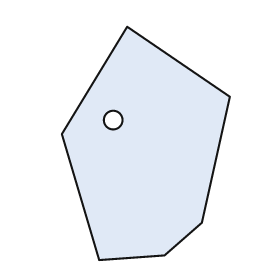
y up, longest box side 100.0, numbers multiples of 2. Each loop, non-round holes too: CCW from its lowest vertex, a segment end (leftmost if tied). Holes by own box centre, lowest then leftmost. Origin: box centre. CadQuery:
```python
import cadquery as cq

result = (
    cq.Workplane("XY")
    .moveTo(-20.0, -50.0)
    .lineTo(8.0, -48.0)
    .lineTo(24.0, -34.0)
    .lineTo(36.0, 20.0)
    .lineTo(-8.0, 50.0)
    .lineTo(-36.0, 4.0)
    .close()
    .moveTo(-14.0, 10.0)
    .circle(4.0)
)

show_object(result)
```